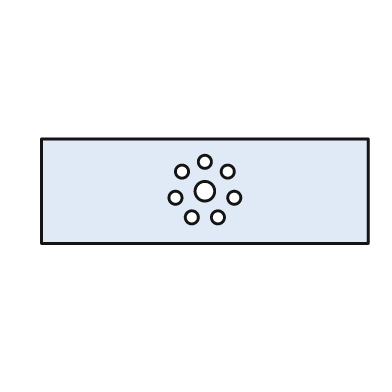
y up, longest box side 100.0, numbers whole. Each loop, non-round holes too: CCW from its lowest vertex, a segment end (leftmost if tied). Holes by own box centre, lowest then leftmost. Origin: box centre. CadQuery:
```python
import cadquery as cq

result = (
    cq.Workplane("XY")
    .moveTo(-50.0, -16.0)
    .lineTo(50.0, -16.0)
    .lineTo(50.0, 16.0)
    .lineTo(-50.0, 16.0)
    .close()
    .moveTo(-4.0, -8.0)
    .circle(2.0)
    .moveTo(4.0, -8.0)
    .circle(2.0)
    .moveTo(-9.0, -2.0)
    .circle(2.0)
    .moveTo(9.0, -2.0)
    .circle(2.0)
    .moveTo(0.0, 0.0)
    .circle(3.0)
    .moveTo(-7.0, 6.0)
    .circle(2.0)
    .moveTo(7.0, 6.0)
    .circle(2.0)
    .moveTo(0.0, 9.0)
    .circle(2.0)
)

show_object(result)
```